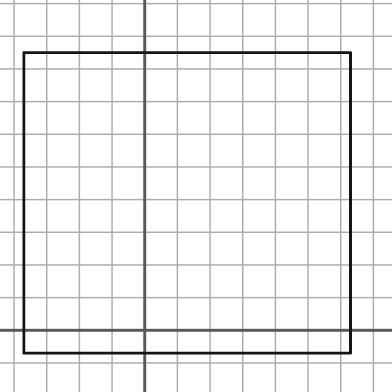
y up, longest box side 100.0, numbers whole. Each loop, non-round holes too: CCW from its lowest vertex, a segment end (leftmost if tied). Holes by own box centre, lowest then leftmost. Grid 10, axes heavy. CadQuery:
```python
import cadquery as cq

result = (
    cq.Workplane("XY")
    .moveTo(-37.0, -7.0)
    .lineTo(63.0, -7.0)
    .lineTo(63.0, 85.0)
    .lineTo(-37.0, 85.0)
    .close()
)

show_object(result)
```